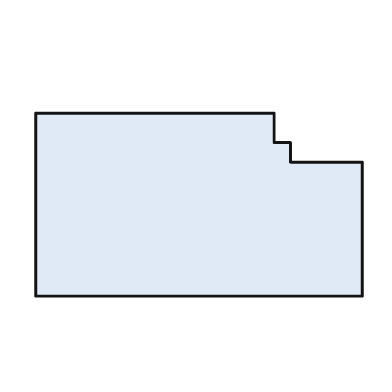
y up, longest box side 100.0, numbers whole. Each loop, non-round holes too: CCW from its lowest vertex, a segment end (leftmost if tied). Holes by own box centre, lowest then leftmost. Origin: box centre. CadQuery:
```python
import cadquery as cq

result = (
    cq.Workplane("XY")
    .moveTo(-50.0, -28.0)
    .lineTo(50.0, -28.0)
    .lineTo(50.0, 13.0)
    .lineTo(28.0, 13.0)
    .lineTo(28.0, 19.0)
    .lineTo(23.0, 19.0)
    .lineTo(23.0, 28.0)
    .lineTo(-50.0, 28.0)
    .close()
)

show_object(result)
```